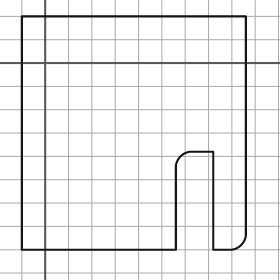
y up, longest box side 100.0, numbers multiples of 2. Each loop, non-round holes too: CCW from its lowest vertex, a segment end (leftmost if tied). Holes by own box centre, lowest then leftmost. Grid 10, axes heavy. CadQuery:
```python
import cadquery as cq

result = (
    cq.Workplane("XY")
    .moveTo(-10.0, -80.0)
    .lineTo(56.0, -80.0)
    .lineTo(56.0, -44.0)
    .threePointArc((58.0, -40.0), (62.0, -38.0))
    .lineTo(72.0, -38.0)
    .lineTo(72.0, -80.0)
    .lineTo(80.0, -80.0)
    .threePointArc((84.0, -78.0), (86.0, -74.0))
    .lineTo(86.0, 20.0)
    .lineTo(-10.0, 20.0)
    .close()
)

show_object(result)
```